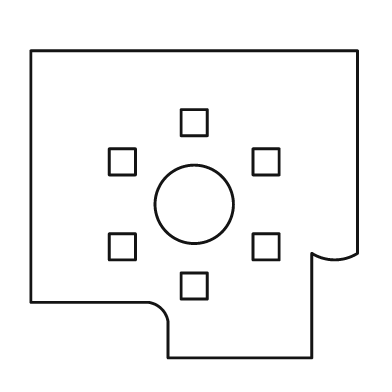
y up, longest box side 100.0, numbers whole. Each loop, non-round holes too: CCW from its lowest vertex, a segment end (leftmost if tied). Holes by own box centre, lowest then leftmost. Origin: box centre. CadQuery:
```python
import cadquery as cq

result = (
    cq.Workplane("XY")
    .moveTo(-8.0, -47.0)
    .lineTo(36.0, -47.0)
    .lineTo(36.0, -15.0)
    .threePointArc((43.0, -17.0), (50.0, -15.0))
    .lineTo(50.0, 47.0)
    .lineTo(-50.0, 47.0)
    .lineTo(-50.0, -30.0)
    .lineTo(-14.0, -30.0)
    .threePointArc((-10.0, -32.0), (-8.0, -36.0))
    .close()
    .moveTo(-4.0, -29.0)
    .lineTo(4.0, -29.0)
    .lineTo(4.0, -21.0)
    .lineTo(-4.0, -21.0)
    .close()
    .moveTo(-26.0, -17.0)
    .lineTo(-18.0, -17.0)
    .lineTo(-18.0, -9.0)
    .lineTo(-26.0, -9.0)
    .close()
    .moveTo(18.0, -17.0)
    .lineTo(26.0, -17.0)
    .lineTo(26.0, -9.0)
    .lineTo(18.0, -9.0)
    .close()
    .moveTo(0.0, 0.0)
    .circle(12.0)
    .moveTo(-26.0, 9.0)
    .lineTo(-18.0, 9.0)
    .lineTo(-18.0, 17.0)
    .lineTo(-26.0, 17.0)
    .close()
    .moveTo(18.0, 9.0)
    .lineTo(26.0, 9.0)
    .lineTo(26.0, 17.0)
    .lineTo(18.0, 17.0)
    .close()
    .moveTo(-4.0, 21.0)
    .lineTo(4.0, 21.0)
    .lineTo(4.0, 29.0)
    .lineTo(-4.0, 29.0)
    .close()
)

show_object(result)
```